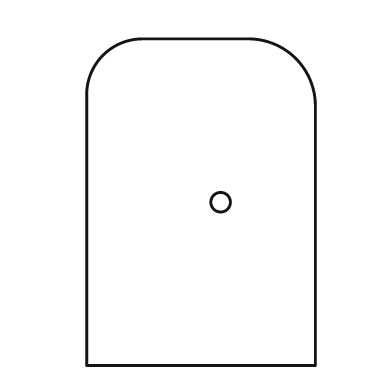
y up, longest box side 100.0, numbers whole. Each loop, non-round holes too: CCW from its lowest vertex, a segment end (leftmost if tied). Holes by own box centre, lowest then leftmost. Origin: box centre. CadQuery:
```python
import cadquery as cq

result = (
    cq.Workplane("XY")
    .moveTo(-35.0, -50.0)
    .lineTo(35.0, -50.0)
    .lineTo(35.0, 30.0)
    .threePointArc((29.0, 44.0), (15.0, 50.0))
    .lineTo(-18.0, 50.0)
    .threePointArc((-30.0, 45.0), (-35.0, 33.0))
    .close()
    .moveTo(6.0, 0.0)
    .circle(3.0)
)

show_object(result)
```